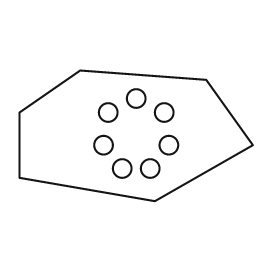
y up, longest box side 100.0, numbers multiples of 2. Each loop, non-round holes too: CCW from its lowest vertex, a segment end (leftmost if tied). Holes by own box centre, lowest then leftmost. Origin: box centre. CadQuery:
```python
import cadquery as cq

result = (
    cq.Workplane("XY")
    .moveTo(8.0, -28.0)
    .lineTo(50.0, -4.0)
    .lineTo(30.0, 24.0)
    .lineTo(-24.0, 28.0)
    .lineTo(-50.0, 10.0)
    .lineTo(-50.0, -18.0)
    .close()
    .moveTo(-6.0, -14.0)
    .circle(4.0)
    .moveTo(6.0, -14.0)
    .circle(4.0)
    .moveTo(-14.0, -4.0)
    .circle(4.0)
    .moveTo(14.0, -4.0)
    .circle(4.0)
    .moveTo(-12.0, 10.0)
    .circle(4.0)
    .moveTo(12.0, 10.0)
    .circle(4.0)
    .moveTo(0.0, 16.0)
    .circle(4.0)
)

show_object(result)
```